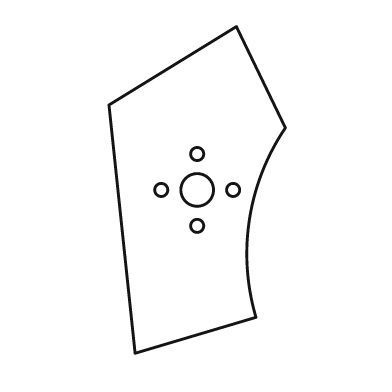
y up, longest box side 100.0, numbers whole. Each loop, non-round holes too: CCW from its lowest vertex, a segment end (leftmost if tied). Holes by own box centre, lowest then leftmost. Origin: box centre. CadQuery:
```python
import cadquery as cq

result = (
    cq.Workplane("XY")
    .moveTo(-19.0, -50.0)
    .lineTo(18.0, -39.0)
    .threePointArc((16.0, -9.0), (27.0, 19.0))
    .lineTo(12.0, 50.0)
    .lineTo(-27.0, 26.0)
    .close()
    .moveTo(0.0, -11.0)
    .circle(2.0)
    .moveTo(-11.0, 0.0)
    .circle(2.0)
    .moveTo(0.0, 0.0)
    .circle(5.0)
    .moveTo(11.0, 0.0)
    .circle(2.0)
    .moveTo(0.0, 11.0)
    .circle(2.0)
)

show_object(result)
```